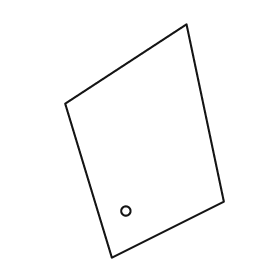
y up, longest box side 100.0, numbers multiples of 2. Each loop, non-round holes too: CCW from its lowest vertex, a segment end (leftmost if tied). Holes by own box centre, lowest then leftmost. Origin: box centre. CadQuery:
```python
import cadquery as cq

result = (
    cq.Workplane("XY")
    .moveTo(-14.0, -50.0)
    .lineTo(34.0, -26.0)
    .lineTo(18.0, 50.0)
    .lineTo(-34.0, 16.0)
    .close()
    .moveTo(-8.0, -30.0)
    .circle(2.0)
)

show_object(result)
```